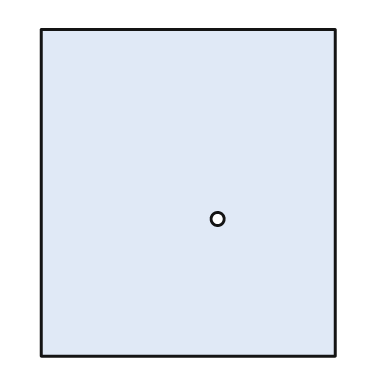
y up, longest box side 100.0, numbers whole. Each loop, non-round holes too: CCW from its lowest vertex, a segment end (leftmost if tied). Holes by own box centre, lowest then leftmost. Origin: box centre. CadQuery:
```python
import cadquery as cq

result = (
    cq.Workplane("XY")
    .moveTo(-45.0, -50.0)
    .lineTo(45.0, -50.0)
    .lineTo(45.0, 50.0)
    .lineTo(-45.0, 50.0)
    .close()
    .moveTo(9.0, -8.0)
    .circle(2.0)
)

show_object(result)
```